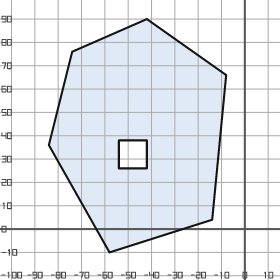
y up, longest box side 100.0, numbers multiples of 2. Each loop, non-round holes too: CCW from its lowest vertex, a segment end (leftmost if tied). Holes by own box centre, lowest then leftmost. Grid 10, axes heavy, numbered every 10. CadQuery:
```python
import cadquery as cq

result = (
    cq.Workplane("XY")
    .moveTo(-58.0, -10.0)
    .lineTo(-14.0, 4.0)
    .lineTo(-8.0, 66.0)
    .lineTo(-42.0, 90.0)
    .lineTo(-74.0, 76.0)
    .lineTo(-84.0, 36.0)
    .close()
    .moveTo(-54.0, 26.0)
    .lineTo(-42.0, 26.0)
    .lineTo(-42.0, 38.0)
    .lineTo(-54.0, 38.0)
    .close()
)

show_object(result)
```